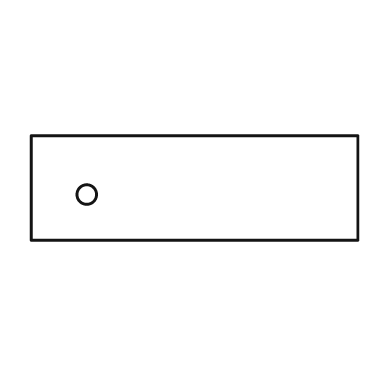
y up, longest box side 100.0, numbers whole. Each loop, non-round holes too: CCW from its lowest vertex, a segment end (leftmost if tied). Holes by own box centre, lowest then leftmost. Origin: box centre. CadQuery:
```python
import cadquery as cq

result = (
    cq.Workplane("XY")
    .moveTo(-50.0, -16.0)
    .lineTo(50.0, -16.0)
    .lineTo(50.0, 16.0)
    .lineTo(-50.0, 16.0)
    .close()
    .moveTo(-33.0, -2.0)
    .circle(3.0)
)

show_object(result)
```